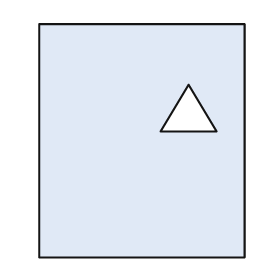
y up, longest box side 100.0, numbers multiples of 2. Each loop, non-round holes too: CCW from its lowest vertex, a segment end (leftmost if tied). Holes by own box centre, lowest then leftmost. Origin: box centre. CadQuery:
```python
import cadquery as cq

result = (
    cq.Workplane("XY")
    .moveTo(-44.0, -50.0)
    .lineTo(44.0, -50.0)
    .lineTo(44.0, 50.0)
    .lineTo(-44.0, 50.0)
    .close()
    .moveTo(8.0, 4.0)
    .lineTo(32.0, 4.0)
    .lineTo(20.0, 24.0)
    .close()
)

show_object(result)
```